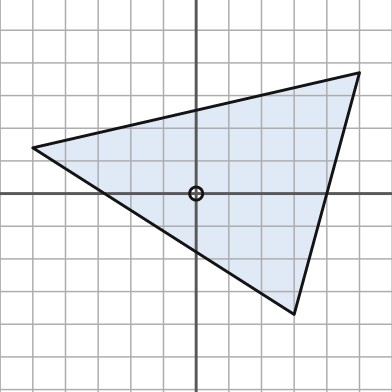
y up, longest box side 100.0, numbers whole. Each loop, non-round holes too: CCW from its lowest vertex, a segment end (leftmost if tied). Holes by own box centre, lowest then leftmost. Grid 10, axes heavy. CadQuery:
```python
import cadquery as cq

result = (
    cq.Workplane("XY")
    .moveTo(30.0, -37.0)
    .lineTo(50.0, 37.0)
    .lineTo(-50.0, 14.0)
    .close()
    .moveTo(0.0, 0.0)
    .circle(2.0)
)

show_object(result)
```